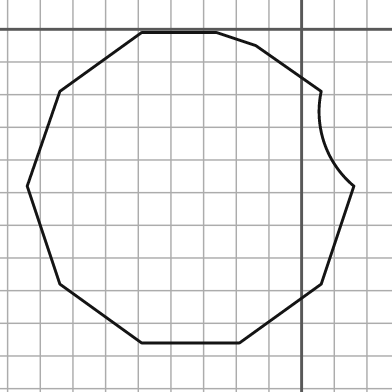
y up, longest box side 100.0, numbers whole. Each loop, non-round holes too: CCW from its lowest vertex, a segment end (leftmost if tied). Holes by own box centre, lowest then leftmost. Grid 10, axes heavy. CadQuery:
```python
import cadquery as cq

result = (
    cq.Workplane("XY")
    .moveTo(-49.0, -96.0)
    .lineTo(-19.0, -96.0)
    .lineTo(6.0, -78.0)
    .lineTo(16.0, -48.0)
    .threePointArc((7.0, -35.0), (6.0, -19.0))
    .lineTo(-14.0, -5.0)
    .lineTo(-26.0, -1.0)
    .lineTo(-49.0, -1.0)
    .lineTo(-74.0, -19.0)
    .lineTo(-84.0, -48.0)
    .lineTo(-74.0, -78.0)
    .close()
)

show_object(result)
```